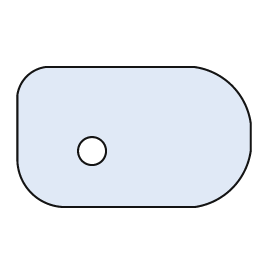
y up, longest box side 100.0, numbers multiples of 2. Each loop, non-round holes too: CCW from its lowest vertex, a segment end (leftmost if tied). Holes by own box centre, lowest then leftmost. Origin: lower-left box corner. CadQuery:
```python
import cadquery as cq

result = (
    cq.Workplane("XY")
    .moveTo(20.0, 0.0)
    .lineTo(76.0, 0.0)
    .threePointArc((92.0, 8.0), (100.0, 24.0))
    .lineTo(100.0, 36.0)
    .threePointArc((92.0, 52.0), (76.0, 60.0))
    .lineTo(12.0, 60.0)
    .threePointArc((4.0, 56.0), (0.0, 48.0))
    .lineTo(0.0, 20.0)
    .threePointArc((6.0, 6.0), (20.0, 0.0))
    .close()
    .moveTo(32.0, 24.0)
    .circle(6.0)
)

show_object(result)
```